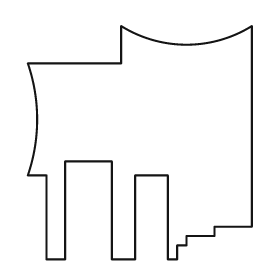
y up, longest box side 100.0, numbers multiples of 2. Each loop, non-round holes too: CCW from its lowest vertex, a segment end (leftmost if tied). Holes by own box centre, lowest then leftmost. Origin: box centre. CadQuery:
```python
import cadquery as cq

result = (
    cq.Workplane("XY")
    .moveTo(-40.0, -50.0)
    .lineTo(-32.0, -50.0)
    .lineTo(-32.0, -8.0)
    .lineTo(-12.0, -8.0)
    .lineTo(-12.0, -50.0)
    .lineTo(-2.0, -50.0)
    .lineTo(-2.0, -14.0)
    .lineTo(12.0, -14.0)
    .lineTo(12.0, -50.0)
    .lineTo(16.0, -50.0)
    .lineTo(16.0, -44.0)
    .lineTo(20.0, -44.0)
    .lineTo(20.0, -40.0)
    .lineTo(32.0, -40.0)
    .lineTo(32.0, -36.0)
    .lineTo(48.0, -36.0)
    .lineTo(48.0, 50.0)
    .threePointArc((20.0, 42.0), (-8.0, 50.0))
    .lineTo(-8.0, 34.0)
    .lineTo(-48.0, 34.0)
    .threePointArc((-44.0, 10.0), (-48.0, -14.0))
    .lineTo(-40.0, -14.0)
    .close()
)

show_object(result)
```